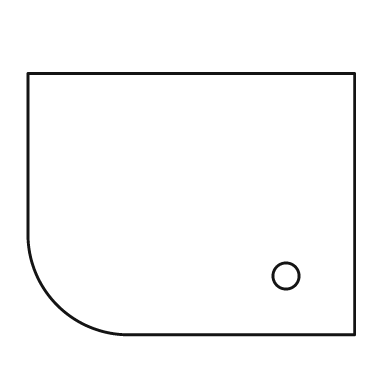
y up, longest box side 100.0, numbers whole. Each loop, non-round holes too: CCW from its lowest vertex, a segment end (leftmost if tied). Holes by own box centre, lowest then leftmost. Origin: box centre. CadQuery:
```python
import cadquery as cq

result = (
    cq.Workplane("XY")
    .moveTo(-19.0, -40.0)
    .lineTo(50.0, -40.0)
    .lineTo(50.0, 40.0)
    .lineTo(-50.0, 40.0)
    .lineTo(-50.0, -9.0)
    .threePointArc((-41.0, -31.0), (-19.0, -40.0))
    .close()
    .moveTo(29.0, -22.0)
    .circle(4.0)
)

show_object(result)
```